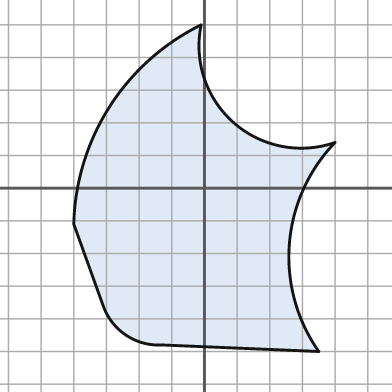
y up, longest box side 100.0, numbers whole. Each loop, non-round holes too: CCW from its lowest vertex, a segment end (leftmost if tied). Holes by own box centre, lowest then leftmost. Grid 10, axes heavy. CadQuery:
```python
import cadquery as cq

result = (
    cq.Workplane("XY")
    .moveTo(35.0, -50.0)
    .threePointArc((26.0, -17.0), (40.0, 14.0))
    .threePointArc((9.0, 20.0), (-1.0, 50.0))
    .threePointArc((-29.0, 25.0), (-40.0, -11.0))
    .lineTo(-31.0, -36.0)
    .threePointArc((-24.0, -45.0), (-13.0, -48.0))
    .close()
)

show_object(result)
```